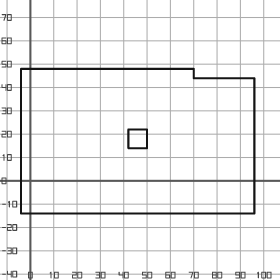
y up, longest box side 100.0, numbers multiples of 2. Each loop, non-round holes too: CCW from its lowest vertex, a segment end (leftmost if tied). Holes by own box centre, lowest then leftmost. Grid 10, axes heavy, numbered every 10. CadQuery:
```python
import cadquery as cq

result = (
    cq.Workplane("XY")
    .moveTo(-4.0, -14.0)
    .lineTo(96.0, -14.0)
    .lineTo(96.0, 44.0)
    .lineTo(70.0, 44.0)
    .lineTo(70.0, 48.0)
    .lineTo(-4.0, 48.0)
    .close()
    .moveTo(42.0, 14.0)
    .lineTo(50.0, 14.0)
    .lineTo(50.0, 22.0)
    .lineTo(42.0, 22.0)
    .close()
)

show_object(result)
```